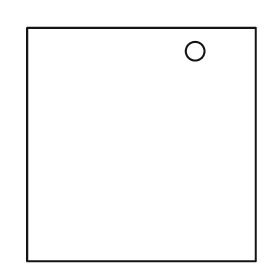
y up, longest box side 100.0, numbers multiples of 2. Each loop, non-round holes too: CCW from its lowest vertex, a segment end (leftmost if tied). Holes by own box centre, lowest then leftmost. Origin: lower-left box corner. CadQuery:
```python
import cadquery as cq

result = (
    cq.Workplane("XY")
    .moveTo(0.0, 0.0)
    .lineTo(98.0, 0.0)
    .lineTo(98.0, 100.0)
    .lineTo(0.0, 100.0)
    .close()
    .moveTo(72.0, 90.0)
    .circle(4.0)
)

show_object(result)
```